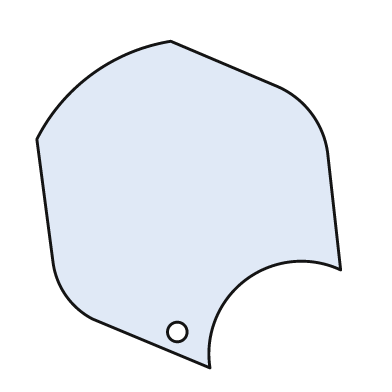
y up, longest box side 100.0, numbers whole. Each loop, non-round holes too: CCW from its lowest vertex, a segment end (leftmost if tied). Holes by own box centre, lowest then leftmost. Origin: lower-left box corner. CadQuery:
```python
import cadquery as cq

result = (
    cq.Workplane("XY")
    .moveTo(53.0, 0.0)
    .threePointArc((64.0, 27.0), (93.0, 30.0))
    .lineTo(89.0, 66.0)
    .threePointArc((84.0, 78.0), (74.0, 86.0))
    .lineTo(41.0, 100.0)
    .threePointArc((17.0, 90.0), (0.0, 70.0))
    .lineTo(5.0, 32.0)
    .threePointArc((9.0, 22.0), (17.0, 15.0))
    .close()
    .moveTo(43.0, 11.0)
    .circle(3.0)
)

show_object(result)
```